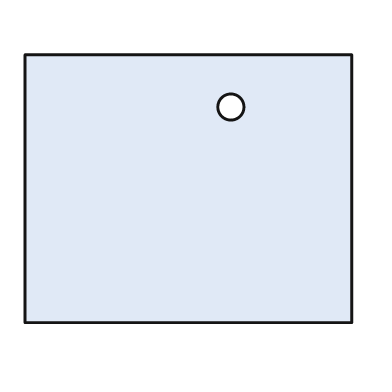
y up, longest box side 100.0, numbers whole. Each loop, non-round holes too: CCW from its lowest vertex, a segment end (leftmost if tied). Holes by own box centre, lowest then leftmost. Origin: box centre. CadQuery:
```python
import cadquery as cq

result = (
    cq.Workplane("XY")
    .moveTo(-50.0, -41.0)
    .lineTo(50.0, -41.0)
    .lineTo(50.0, 41.0)
    .lineTo(-50.0, 41.0)
    .close()
    .moveTo(13.0, 25.0)
    .circle(4.0)
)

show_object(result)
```